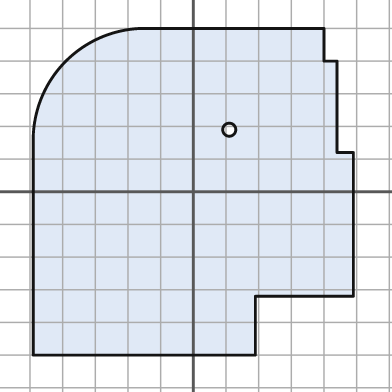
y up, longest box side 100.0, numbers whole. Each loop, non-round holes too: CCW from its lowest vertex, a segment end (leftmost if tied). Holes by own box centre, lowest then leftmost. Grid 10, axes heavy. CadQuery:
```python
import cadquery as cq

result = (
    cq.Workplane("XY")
    .moveTo(-49.0, -50.0)
    .lineTo(19.0, -50.0)
    .lineTo(19.0, -32.0)
    .lineTo(49.0, -32.0)
    .lineTo(49.0, 12.0)
    .lineTo(44.0, 12.0)
    .lineTo(44.0, 40.0)
    .lineTo(40.0, 40.0)
    .lineTo(40.0, 50.0)
    .lineTo(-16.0, 50.0)
    .threePointArc((-39.0, 40.0), (-49.0, 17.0))
    .close()
    .moveTo(11.0, 19.0)
    .circle(2.0)
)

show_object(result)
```